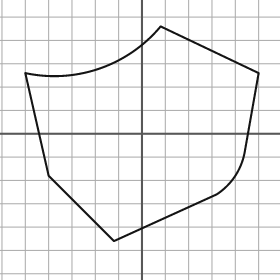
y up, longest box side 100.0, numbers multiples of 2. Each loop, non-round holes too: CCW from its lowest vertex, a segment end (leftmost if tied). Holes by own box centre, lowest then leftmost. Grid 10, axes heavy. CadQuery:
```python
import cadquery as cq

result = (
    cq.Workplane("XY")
    .moveTo(-12.0, -46.0)
    .lineTo(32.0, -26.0)
    .threePointArc((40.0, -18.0), (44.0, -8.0))
    .lineTo(50.0, 26.0)
    .lineTo(8.0, 46.0)
    .threePointArc((-18.0, 28.0), (-50.0, 26.0))
    .lineTo(-40.0, -18.0)
    .close()
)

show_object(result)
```